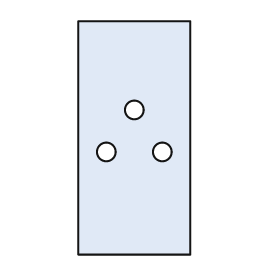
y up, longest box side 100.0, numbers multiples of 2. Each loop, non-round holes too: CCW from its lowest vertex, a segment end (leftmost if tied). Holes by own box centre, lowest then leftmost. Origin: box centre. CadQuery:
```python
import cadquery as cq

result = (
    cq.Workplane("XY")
    .moveTo(-24.0, -50.0)
    .lineTo(24.0, -50.0)
    .lineTo(24.0, 50.0)
    .lineTo(-24.0, 50.0)
    .close()
    .moveTo(-12.0, -6.0)
    .circle(4.0)
    .moveTo(12.0, -6.0)
    .circle(4.0)
    .moveTo(0.0, 12.0)
    .circle(4.0)
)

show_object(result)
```